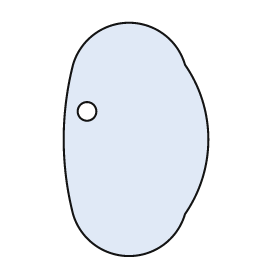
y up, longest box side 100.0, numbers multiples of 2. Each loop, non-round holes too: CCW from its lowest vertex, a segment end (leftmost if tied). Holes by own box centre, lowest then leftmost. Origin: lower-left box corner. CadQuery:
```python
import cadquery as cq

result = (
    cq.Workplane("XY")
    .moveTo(4.0, 18.0)
    .threePointArc((28.0, 0.0), (52.0, 18.0))
    .threePointArc((62.0, 50.0), (52.0, 82.0))
    .threePointArc((28.0, 100.0), (4.0, 82.0))
    .threePointArc((0.0, 50.0), (4.0, 18.0))
    .close()
    .moveTo(10.0, 62.0)
    .circle(4.0)
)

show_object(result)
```